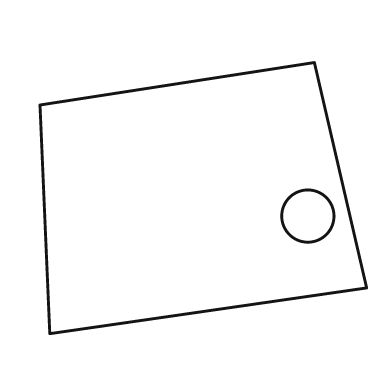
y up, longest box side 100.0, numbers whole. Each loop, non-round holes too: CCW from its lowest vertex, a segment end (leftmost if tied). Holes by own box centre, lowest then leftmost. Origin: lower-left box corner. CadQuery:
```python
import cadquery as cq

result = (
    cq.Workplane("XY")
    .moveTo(3.0, 0.0)
    .lineTo(100.0, 14.0)
    .lineTo(84.0, 83.0)
    .lineTo(0.0, 70.0)
    .close()
    .moveTo(82.0, 36.0)
    .circle(8.0)
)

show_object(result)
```